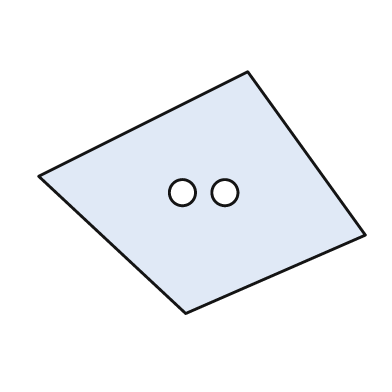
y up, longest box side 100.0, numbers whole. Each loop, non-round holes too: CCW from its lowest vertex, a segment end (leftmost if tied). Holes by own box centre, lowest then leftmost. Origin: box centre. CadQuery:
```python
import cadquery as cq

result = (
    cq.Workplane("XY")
    .moveTo(-5.0, -37.0)
    .lineTo(50.0, -13.0)
    .lineTo(14.0, 37.0)
    .lineTo(-50.0, 5.0)
    .close()
    .moveTo(-6.0, 0.0)
    .circle(4.0)
    .moveTo(7.0, 0.0)
    .circle(4.0)
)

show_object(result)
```